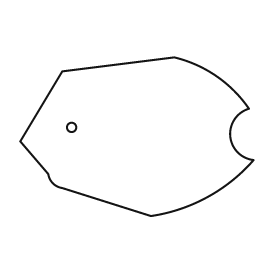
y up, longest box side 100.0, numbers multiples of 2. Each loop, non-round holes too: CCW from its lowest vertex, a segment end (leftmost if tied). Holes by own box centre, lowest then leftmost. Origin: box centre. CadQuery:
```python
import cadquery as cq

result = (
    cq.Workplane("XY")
    .moveTo(6.0, -34.0)
    .threePointArc((30.0, -26.0), (50.0, -10.0))
    .threePointArc((40.0, 0.0), (48.0, 12.0))
    .threePointArc((34.0, 26.0), (16.0, 34.0))
    .lineTo(-32.0, 28.0)
    .lineTo(-50.0, -2.0)
    .lineTo(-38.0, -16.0)
    .threePointArc((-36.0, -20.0), (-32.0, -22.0))
    .close()
    .moveTo(-28.0, 4.0)
    .circle(2.0)
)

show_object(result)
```